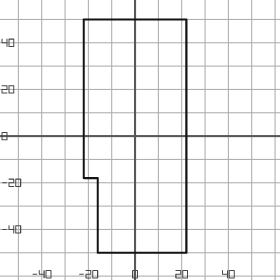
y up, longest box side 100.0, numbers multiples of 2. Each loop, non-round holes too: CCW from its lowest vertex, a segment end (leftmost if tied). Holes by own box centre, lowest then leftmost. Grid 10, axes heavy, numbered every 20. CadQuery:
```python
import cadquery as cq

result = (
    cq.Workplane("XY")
    .moveTo(-16.0, -50.0)
    .lineTo(22.0, -50.0)
    .lineTo(22.0, 50.0)
    .lineTo(-22.0, 50.0)
    .lineTo(-22.0, -18.0)
    .lineTo(-16.0, -18.0)
    .close()
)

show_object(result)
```